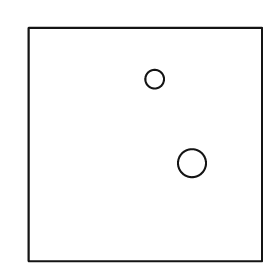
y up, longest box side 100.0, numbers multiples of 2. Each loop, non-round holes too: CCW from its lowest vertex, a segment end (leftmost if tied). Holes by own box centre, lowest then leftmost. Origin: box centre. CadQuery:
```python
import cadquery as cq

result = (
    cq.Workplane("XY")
    .moveTo(-50.0, -50.0)
    .lineTo(50.0, -50.0)
    .lineTo(50.0, 50.0)
    .lineTo(-50.0, 50.0)
    .close()
    .moveTo(20.0, -8.0)
    .circle(6.0)
    .moveTo(4.0, 28.0)
    .circle(4.0)
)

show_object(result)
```